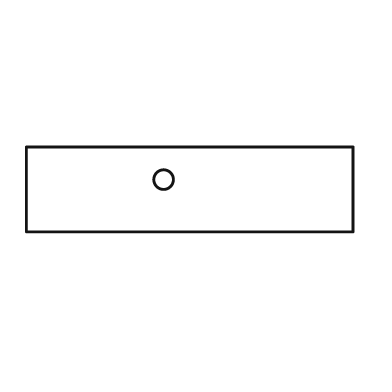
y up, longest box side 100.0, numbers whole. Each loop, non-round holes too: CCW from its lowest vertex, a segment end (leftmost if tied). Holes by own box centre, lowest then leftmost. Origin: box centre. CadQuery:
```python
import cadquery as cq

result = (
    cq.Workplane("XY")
    .moveTo(-50.0, -13.0)
    .lineTo(50.0, -13.0)
    .lineTo(50.0, 13.0)
    .lineTo(-50.0, 13.0)
    .close()
    .moveTo(-8.0, 3.0)
    .circle(3.0)
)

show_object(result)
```